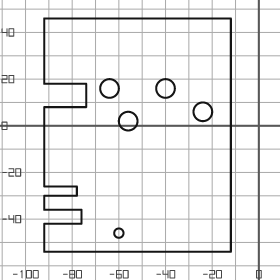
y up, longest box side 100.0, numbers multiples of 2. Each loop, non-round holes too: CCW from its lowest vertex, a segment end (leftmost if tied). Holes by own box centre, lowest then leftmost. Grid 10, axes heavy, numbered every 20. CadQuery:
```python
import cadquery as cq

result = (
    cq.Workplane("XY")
    .moveTo(-92.0, -54.0)
    .lineTo(-12.0, -54.0)
    .lineTo(-12.0, 46.0)
    .lineTo(-92.0, 46.0)
    .lineTo(-92.0, 18.0)
    .lineTo(-74.0, 18.0)
    .lineTo(-74.0, 8.0)
    .lineTo(-92.0, 8.0)
    .lineTo(-92.0, -26.0)
    .lineTo(-78.0, -26.0)
    .lineTo(-78.0, -30.0)
    .lineTo(-92.0, -30.0)
    .lineTo(-92.0, -36.0)
    .lineTo(-76.0, -36.0)
    .lineTo(-76.0, -42.0)
    .lineTo(-92.0, -42.0)
    .close()
    .moveTo(-60.0, -46.0)
    .circle(2.0)
    .moveTo(-56.0, 2.0)
    .circle(4.0)
    .moveTo(-24.0, 6.0)
    .circle(4.0)
    .moveTo(-64.0, 16.0)
    .circle(4.0)
    .moveTo(-40.0, 16.0)
    .circle(4.0)
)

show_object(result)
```